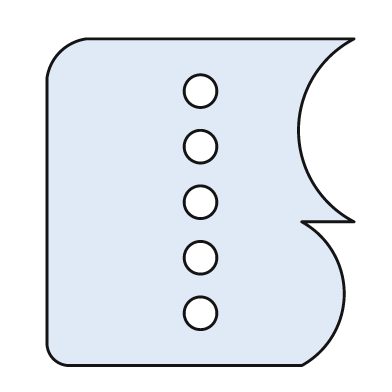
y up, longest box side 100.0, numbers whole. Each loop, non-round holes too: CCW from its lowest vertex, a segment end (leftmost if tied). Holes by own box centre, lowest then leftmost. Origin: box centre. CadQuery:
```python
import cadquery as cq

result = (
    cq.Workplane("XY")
    .moveTo(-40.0, -50.0)
    .lineTo(31.0, -50.0)
    .threePointArc((44.0, -28.0), (31.0, -6.0))
    .lineTo(47.0, -6.0)
    .threePointArc((30.0, 22.0), (47.0, 50.0))
    .lineTo(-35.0, 50.0)
    .threePointArc((-43.0, 46.0), (-47.0, 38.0))
    .lineTo(-47.0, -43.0)
    .threePointArc((-45.0, -48.0), (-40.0, -50.0))
    .close()
    .moveTo(0.0, -34.0)
    .circle(5.0)
    .moveTo(0.0, -17.0)
    .circle(5.0)
    .moveTo(0.0, 0.0)
    .circle(5.0)
    .moveTo(0.0, 17.0)
    .circle(5.0)
    .moveTo(0.0, 34.0)
    .circle(5.0)
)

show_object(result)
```